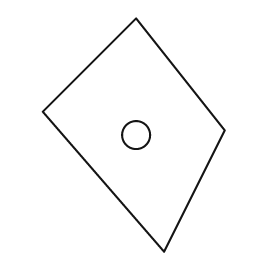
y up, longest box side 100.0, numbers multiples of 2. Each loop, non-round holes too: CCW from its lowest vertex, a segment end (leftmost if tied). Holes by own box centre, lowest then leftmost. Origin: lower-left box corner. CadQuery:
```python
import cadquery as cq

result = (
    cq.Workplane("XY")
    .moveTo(52.0, 0.0)
    .lineTo(78.0, 52.0)
    .lineTo(40.0, 100.0)
    .lineTo(0.0, 60.0)
    .close()
    .moveTo(40.0, 50.0)
    .circle(6.0)
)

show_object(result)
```